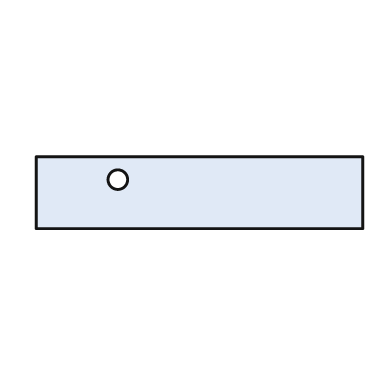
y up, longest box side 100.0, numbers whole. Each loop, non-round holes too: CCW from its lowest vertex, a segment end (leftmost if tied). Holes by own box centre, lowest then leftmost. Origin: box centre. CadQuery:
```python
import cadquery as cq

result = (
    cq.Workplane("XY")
    .moveTo(-50.0, -11.0)
    .lineTo(50.0, -11.0)
    .lineTo(50.0, 11.0)
    .lineTo(-50.0, 11.0)
    .close()
    .moveTo(-25.0, 4.0)
    .circle(3.0)
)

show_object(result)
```